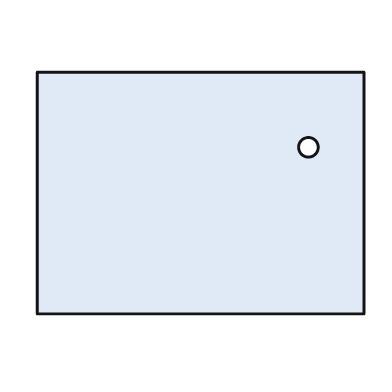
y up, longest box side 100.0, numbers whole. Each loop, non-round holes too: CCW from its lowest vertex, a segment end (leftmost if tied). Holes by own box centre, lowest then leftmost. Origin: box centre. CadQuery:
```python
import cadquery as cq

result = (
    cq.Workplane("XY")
    .moveTo(-50.0, -37.0)
    .lineTo(50.0, -37.0)
    .lineTo(50.0, 37.0)
    .lineTo(-50.0, 37.0)
    .close()
    .moveTo(33.0, 14.0)
    .circle(3.0)
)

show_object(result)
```